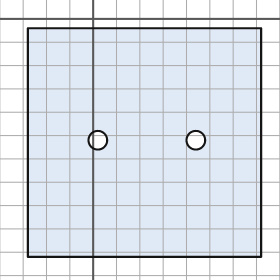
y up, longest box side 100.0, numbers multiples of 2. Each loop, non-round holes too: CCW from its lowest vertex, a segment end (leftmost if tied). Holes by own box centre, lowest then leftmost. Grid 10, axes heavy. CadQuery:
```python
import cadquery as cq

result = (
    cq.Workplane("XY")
    .moveTo(-28.0, -102.0)
    .lineTo(72.0, -102.0)
    .lineTo(72.0, -4.0)
    .lineTo(-28.0, -4.0)
    .close()
    .moveTo(2.0, -52.0)
    .circle(4.0)
    .moveTo(44.0, -52.0)
    .circle(4.0)
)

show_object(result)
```